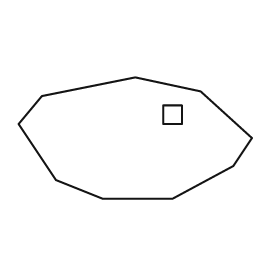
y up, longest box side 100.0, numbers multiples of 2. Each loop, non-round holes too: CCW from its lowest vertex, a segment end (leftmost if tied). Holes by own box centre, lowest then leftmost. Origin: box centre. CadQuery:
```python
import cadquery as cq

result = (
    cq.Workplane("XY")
    .moveTo(-14.0, -26.0)
    .lineTo(16.0, -26.0)
    .lineTo(42.0, -12.0)
    .lineTo(50.0, 0.0)
    .lineTo(28.0, 20.0)
    .lineTo(0.0, 26.0)
    .lineTo(-40.0, 18.0)
    .lineTo(-50.0, 6.0)
    .lineTo(-34.0, -18.0)
    .close()
    .moveTo(12.0, 6.0)
    .lineTo(20.0, 6.0)
    .lineTo(20.0, 14.0)
    .lineTo(12.0, 14.0)
    .close()
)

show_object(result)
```